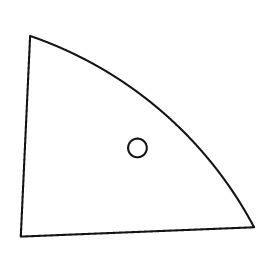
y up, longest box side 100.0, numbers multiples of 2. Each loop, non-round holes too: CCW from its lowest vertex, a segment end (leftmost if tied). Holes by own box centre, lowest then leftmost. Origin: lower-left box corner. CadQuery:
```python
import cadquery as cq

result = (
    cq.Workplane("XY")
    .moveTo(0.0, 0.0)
    .lineTo(100.0, 4.0)
    .threePointArc((60.0, 54.0), (4.0, 86.0))
    .close()
    .moveTo(50.0, 38.0)
    .circle(4.0)
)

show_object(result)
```